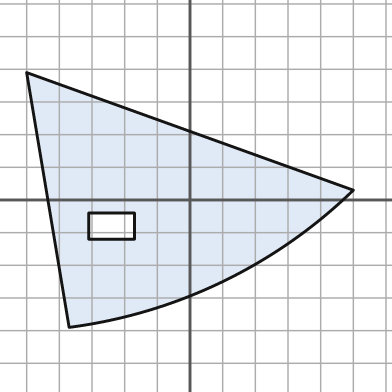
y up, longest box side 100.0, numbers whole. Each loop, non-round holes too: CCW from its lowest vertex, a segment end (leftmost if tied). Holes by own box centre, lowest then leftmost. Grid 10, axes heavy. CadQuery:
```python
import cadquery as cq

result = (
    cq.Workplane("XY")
    .moveTo(-37.0, -39.0)
    .threePointArc((10.0, -25.0), (50.0, 3.0))
    .lineTo(-50.0, 39.0)
    .close()
    .moveTo(-31.0, -12.0)
    .lineTo(-17.0, -12.0)
    .lineTo(-17.0, -4.0)
    .lineTo(-31.0, -4.0)
    .close()
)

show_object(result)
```